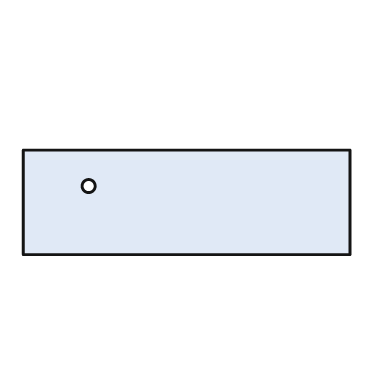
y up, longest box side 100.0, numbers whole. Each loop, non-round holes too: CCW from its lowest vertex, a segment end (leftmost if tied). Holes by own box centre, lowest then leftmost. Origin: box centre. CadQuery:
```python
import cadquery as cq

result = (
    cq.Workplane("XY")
    .moveTo(-50.0, -16.0)
    .lineTo(50.0, -16.0)
    .lineTo(50.0, 16.0)
    .lineTo(-50.0, 16.0)
    .close()
    .moveTo(-30.0, 5.0)
    .circle(2.0)
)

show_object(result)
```